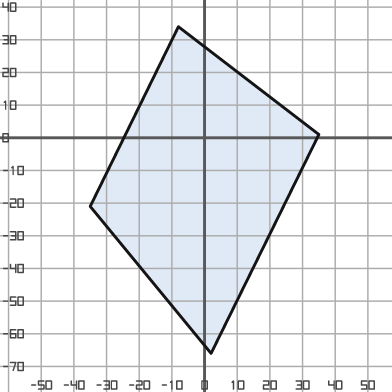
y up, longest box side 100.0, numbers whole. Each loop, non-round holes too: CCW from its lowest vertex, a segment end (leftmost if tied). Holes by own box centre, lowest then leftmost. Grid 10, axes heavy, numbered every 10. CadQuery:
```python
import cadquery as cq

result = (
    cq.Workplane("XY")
    .moveTo(2.0, -66.0)
    .lineTo(35.0, 1.0)
    .lineTo(-8.0, 34.0)
    .lineTo(-35.0, -21.0)
    .close()
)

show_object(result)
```